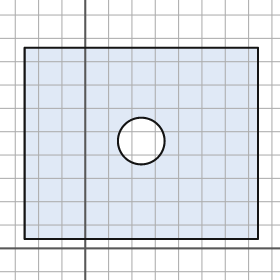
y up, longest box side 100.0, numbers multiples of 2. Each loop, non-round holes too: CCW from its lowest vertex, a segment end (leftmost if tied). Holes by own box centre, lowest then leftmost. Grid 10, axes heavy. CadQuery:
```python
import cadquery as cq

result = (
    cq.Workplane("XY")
    .moveTo(-26.0, 4.0)
    .lineTo(74.0, 4.0)
    .lineTo(74.0, 86.0)
    .lineTo(-26.0, 86.0)
    .close()
    .moveTo(24.0, 46.0)
    .circle(10.0)
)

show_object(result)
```